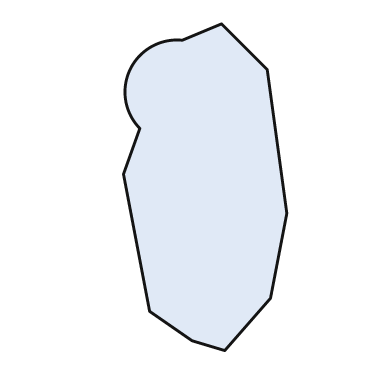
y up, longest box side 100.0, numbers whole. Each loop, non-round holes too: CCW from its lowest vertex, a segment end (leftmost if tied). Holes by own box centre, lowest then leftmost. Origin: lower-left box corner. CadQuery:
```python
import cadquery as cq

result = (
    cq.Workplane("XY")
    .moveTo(31.0, 0.0)
    .lineTo(45.0, 16.0)
    .lineTo(50.0, 42.0)
    .lineTo(44.0, 86.0)
    .lineTo(30.0, 100.0)
    .lineTo(18.0, 95.0)
    .threePointArc((2.0, 86.0), (5.0, 68.0))
    .lineTo(0.0, 54.0)
    .lineTo(8.0, 12.0)
    .lineTo(21.0, 3.0)
    .close()
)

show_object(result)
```